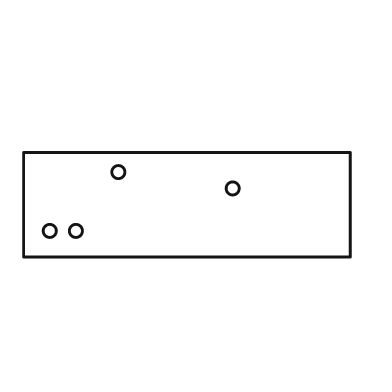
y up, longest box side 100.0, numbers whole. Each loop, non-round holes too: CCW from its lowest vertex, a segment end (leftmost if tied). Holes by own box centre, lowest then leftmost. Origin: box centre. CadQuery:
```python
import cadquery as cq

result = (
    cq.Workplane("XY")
    .moveTo(-50.0, -16.0)
    .lineTo(50.0, -16.0)
    .lineTo(50.0, 16.0)
    .lineTo(-50.0, 16.0)
    .close()
    .moveTo(-42.0, -8.0)
    .circle(2.0)
    .moveTo(-34.0, -8.0)
    .circle(2.0)
    .moveTo(14.0, 5.0)
    .circle(2.0)
    .moveTo(-21.0, 10.0)
    .circle(2.0)
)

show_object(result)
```